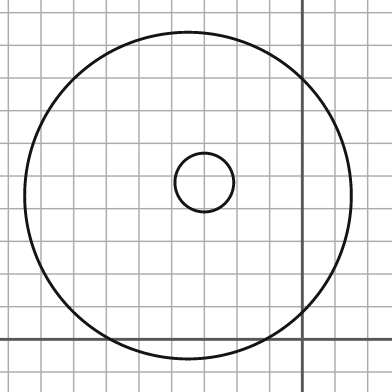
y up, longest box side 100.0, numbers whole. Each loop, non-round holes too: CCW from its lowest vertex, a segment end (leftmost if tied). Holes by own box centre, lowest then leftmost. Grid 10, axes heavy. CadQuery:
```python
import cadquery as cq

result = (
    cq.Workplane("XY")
    .moveTo(-35.0, 44.0)
    .circle(50.0)
    .moveTo(-30.0, 48.0)
    .circle(9.0)
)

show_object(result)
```